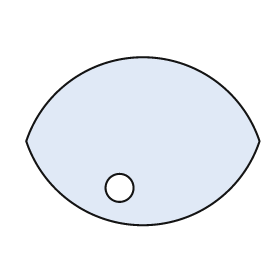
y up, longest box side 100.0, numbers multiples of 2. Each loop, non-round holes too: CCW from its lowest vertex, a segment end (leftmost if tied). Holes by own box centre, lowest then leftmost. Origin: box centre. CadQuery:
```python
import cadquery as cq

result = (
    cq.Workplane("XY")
    .moveTo(-50.0, 0.0)
    .threePointArc((0.0, -36.0), (50.0, 0.0))
    .threePointArc((0.0, 36.0), (-50.0, 0.0))
    .close()
    .moveTo(-10.0, -20.0)
    .circle(6.0)
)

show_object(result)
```